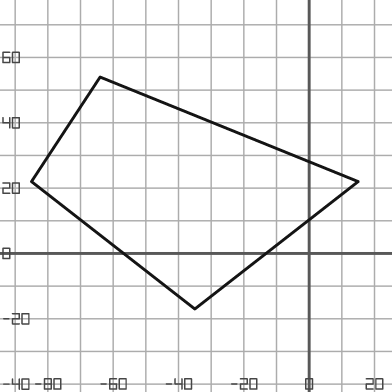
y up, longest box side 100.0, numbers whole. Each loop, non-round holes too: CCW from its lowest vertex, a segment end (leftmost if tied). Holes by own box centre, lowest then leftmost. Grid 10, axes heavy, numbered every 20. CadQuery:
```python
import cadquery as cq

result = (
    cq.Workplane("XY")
    .moveTo(-35.0, -17.0)
    .lineTo(15.0, 22.0)
    .lineTo(-64.0, 54.0)
    .lineTo(-85.0, 22.0)
    .close()
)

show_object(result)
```